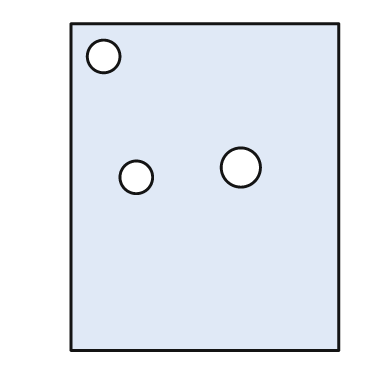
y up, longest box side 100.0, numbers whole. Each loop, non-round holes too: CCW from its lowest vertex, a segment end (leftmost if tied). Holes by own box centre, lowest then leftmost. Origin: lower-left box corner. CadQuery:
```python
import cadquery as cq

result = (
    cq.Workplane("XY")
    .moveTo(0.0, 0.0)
    .lineTo(82.0, 0.0)
    .lineTo(82.0, 100.0)
    .lineTo(0.0, 100.0)
    .close()
    .moveTo(20.0, 53.0)
    .circle(5.0)
    .moveTo(52.0, 56.0)
    .circle(6.0)
    .moveTo(10.0, 90.0)
    .circle(5.0)
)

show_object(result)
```